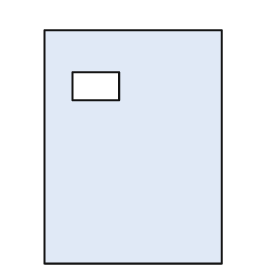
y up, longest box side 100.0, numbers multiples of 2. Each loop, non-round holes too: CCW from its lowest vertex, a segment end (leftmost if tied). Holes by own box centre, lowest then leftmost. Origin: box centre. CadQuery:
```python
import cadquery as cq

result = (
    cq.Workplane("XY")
    .moveTo(-38.0, -50.0)
    .lineTo(38.0, -50.0)
    .lineTo(38.0, 50.0)
    .lineTo(-38.0, 50.0)
    .close()
    .moveTo(-26.0, 20.0)
    .lineTo(-6.0, 20.0)
    .lineTo(-6.0, 32.0)
    .lineTo(-26.0, 32.0)
    .close()
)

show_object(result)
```